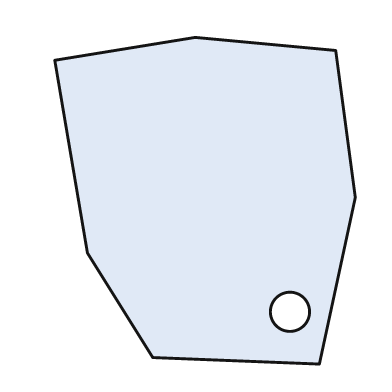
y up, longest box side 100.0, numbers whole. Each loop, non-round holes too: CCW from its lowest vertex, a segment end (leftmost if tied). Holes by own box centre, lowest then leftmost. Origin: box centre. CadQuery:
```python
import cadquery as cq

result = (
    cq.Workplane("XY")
    .moveTo(35.0, -50.0)
    .lineTo(46.0, 1.0)
    .lineTo(40.0, 46.0)
    .lineTo(-3.0, 50.0)
    .lineTo(-46.0, 43.0)
    .lineTo(-36.0, -16.0)
    .lineTo(-16.0, -48.0)
    .close()
    .moveTo(26.0, -34.0)
    .circle(6.0)
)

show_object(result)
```